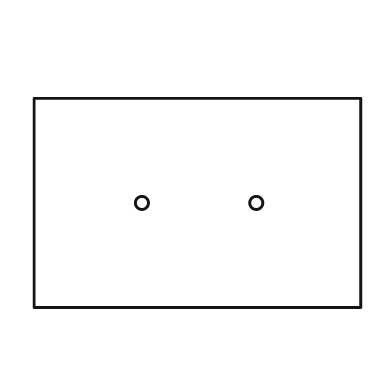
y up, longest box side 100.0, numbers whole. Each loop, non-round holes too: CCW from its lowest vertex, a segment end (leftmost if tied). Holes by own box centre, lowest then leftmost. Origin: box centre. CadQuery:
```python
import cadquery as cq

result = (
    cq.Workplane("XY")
    .moveTo(-50.0, -32.0)
    .lineTo(50.0, -32.0)
    .lineTo(50.0, 32.0)
    .lineTo(-50.0, 32.0)
    .close()
    .moveTo(-17.0, 0.0)
    .circle(2.0)
    .moveTo(18.0, 0.0)
    .circle(2.0)
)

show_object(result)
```